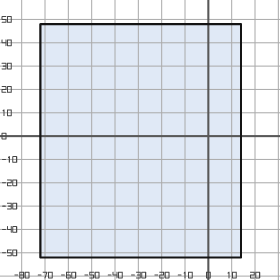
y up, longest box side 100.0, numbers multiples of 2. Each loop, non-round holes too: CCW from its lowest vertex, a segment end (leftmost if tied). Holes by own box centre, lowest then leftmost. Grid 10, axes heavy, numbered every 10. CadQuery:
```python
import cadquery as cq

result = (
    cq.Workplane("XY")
    .moveTo(-72.0, -52.0)
    .lineTo(14.0, -52.0)
    .lineTo(14.0, 48.0)
    .lineTo(-72.0, 48.0)
    .close()
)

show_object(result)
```